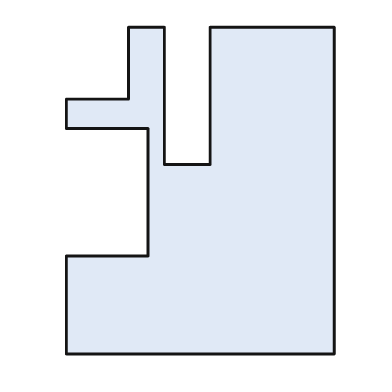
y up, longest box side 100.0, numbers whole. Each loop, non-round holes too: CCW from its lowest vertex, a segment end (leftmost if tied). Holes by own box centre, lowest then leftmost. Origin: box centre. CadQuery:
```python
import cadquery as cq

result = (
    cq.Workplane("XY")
    .moveTo(-41.0, -50.0)
    .lineTo(41.0, -50.0)
    .lineTo(41.0, 50.0)
    .lineTo(3.0, 50.0)
    .lineTo(3.0, 8.0)
    .lineTo(-11.0, 8.0)
    .lineTo(-11.0, 50.0)
    .lineTo(-22.0, 50.0)
    .lineTo(-22.0, 28.0)
    .lineTo(-41.0, 28.0)
    .lineTo(-41.0, 19.0)
    .lineTo(-16.0, 19.0)
    .lineTo(-16.0, -20.0)
    .lineTo(-41.0, -20.0)
    .close()
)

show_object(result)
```